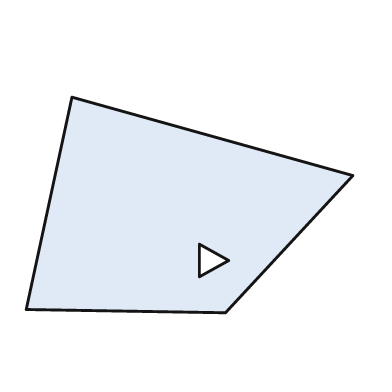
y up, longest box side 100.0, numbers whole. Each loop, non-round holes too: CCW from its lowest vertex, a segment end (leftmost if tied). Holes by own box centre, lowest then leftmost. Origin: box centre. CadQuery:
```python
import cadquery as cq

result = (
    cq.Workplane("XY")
    .moveTo(11.0, -33.0)
    .lineTo(50.0, 9.0)
    .lineTo(-36.0, 33.0)
    .lineTo(-50.0, -32.0)
    .close()
    .moveTo(3.0, -22.0)
    .lineTo(12.0, -17.0)
    .lineTo(3.0, -12.0)
    .close()
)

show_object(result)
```